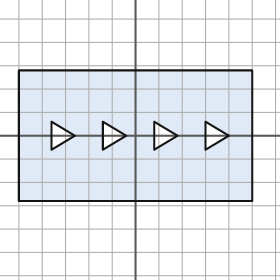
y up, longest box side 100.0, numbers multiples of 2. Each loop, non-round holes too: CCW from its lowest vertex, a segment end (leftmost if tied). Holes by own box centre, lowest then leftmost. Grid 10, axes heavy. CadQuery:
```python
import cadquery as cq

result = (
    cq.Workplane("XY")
    .moveTo(-50.0, -28.0)
    .lineTo(50.0, -28.0)
    .lineTo(50.0, 28.0)
    .lineTo(-50.0, 28.0)
    .close()
    .moveTo(-36.0, -6.0)
    .lineTo(-26.0, 0.0)
    .lineTo(-36.0, 6.0)
    .close()
    .moveTo(-14.0, -6.0)
    .lineTo(-4.0, 0.0)
    .lineTo(-14.0, 6.0)
    .close()
    .moveTo(8.0, -6.0)
    .lineTo(18.0, 0.0)
    .lineTo(8.0, 6.0)
    .close()
    .moveTo(30.0, -6.0)
    .lineTo(40.0, 0.0)
    .lineTo(30.0, 6.0)
    .close()
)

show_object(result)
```